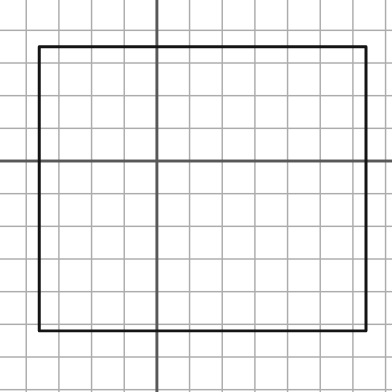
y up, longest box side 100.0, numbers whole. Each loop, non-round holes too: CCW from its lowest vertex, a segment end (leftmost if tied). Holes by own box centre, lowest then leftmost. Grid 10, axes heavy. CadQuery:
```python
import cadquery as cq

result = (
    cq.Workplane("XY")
    .moveTo(-36.0, -52.0)
    .lineTo(64.0, -52.0)
    .lineTo(64.0, 35.0)
    .lineTo(-36.0, 35.0)
    .close()
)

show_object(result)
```